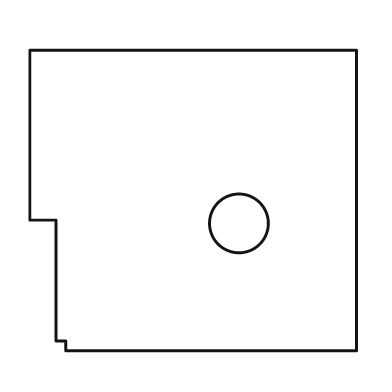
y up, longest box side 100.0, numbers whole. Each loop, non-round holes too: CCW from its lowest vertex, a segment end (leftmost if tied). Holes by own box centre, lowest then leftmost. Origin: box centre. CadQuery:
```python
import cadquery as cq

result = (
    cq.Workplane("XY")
    .moveTo(-39.0, -46.0)
    .lineTo(50.0, -46.0)
    .lineTo(50.0, 46.0)
    .lineTo(-50.0, 46.0)
    .lineTo(-50.0, -6.0)
    .lineTo(-42.0, -6.0)
    .lineTo(-42.0, -43.0)
    .lineTo(-39.0, -43.0)
    .close()
    .moveTo(14.0, -7.0)
    .circle(9.0)
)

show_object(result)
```